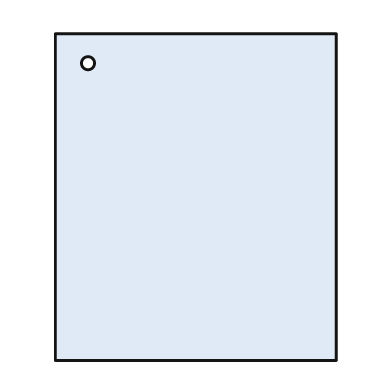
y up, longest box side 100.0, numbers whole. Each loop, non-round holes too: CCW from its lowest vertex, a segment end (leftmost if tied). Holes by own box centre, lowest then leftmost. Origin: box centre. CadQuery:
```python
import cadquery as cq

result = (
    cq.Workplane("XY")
    .moveTo(-43.0, -50.0)
    .lineTo(43.0, -50.0)
    .lineTo(43.0, 50.0)
    .lineTo(-43.0, 50.0)
    .close()
    .moveTo(-33.0, 41.0)
    .circle(2.0)
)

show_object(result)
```